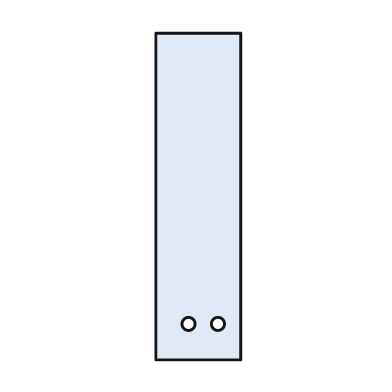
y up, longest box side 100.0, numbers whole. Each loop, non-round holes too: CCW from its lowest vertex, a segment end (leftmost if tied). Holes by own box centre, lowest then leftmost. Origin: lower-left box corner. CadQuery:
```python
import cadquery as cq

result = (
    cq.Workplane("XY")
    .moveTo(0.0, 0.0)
    .lineTo(26.0, 0.0)
    .lineTo(26.0, 100.0)
    .lineTo(0.0, 100.0)
    .close()
    .moveTo(10.0, 11.0)
    .circle(2.0)
    .moveTo(19.0, 11.0)
    .circle(2.0)
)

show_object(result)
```